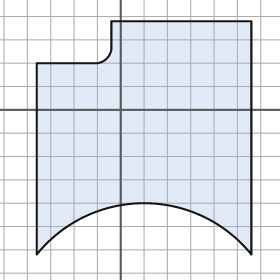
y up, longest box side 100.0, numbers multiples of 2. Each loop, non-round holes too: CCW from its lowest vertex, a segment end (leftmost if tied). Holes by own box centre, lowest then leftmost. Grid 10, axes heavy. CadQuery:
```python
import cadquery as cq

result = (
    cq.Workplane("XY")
    .moveTo(-36.0, -62.0)
    .threePointArc((10.0, -40.0), (56.0, -62.0))
    .lineTo(56.0, 38.0)
    .lineTo(-4.0, 38.0)
    .lineTo(-4.0, 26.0)
    .threePointArc((-6.0, 22.0), (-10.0, 20.0))
    .lineTo(-36.0, 20.0)
    .close()
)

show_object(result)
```